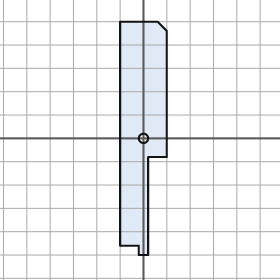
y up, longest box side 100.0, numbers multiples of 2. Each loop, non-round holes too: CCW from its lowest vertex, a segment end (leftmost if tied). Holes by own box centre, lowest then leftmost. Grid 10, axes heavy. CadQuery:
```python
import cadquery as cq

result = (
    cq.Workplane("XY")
    .moveTo(-2.0, -50.0)
    .lineTo(2.0, -50.0)
    .lineTo(2.0, -8.0)
    .lineTo(10.0, -8.0)
    .lineTo(10.0, 46.0)
    .lineTo(6.0, 50.0)
    .lineTo(-10.0, 50.0)
    .lineTo(-10.0, -46.0)
    .lineTo(-2.0, -46.0)
    .close()
    .moveTo(0.0, 0.0)
    .circle(2.0)
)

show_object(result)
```